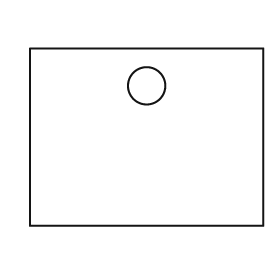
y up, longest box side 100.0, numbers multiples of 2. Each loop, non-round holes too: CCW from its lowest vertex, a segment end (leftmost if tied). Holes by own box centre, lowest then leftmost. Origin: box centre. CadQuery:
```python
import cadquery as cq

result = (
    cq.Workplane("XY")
    .moveTo(-50.0, -38.0)
    .lineTo(50.0, -38.0)
    .lineTo(50.0, 38.0)
    .lineTo(-50.0, 38.0)
    .close()
    .moveTo(0.0, 22.0)
    .circle(8.0)
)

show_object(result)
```